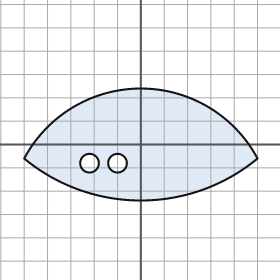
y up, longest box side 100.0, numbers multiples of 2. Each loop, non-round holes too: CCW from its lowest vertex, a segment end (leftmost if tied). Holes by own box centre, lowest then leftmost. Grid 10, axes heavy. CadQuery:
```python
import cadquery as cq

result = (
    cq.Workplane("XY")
    .moveTo(-50.0, -6.0)
    .threePointArc((0.0, -24.0), (50.0, -6.0))
    .threePointArc((0.0, 24.0), (-50.0, -6.0))
    .close()
    .moveTo(-22.0, -8.0)
    .circle(4.0)
    .moveTo(-10.0, -8.0)
    .circle(4.0)
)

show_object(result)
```